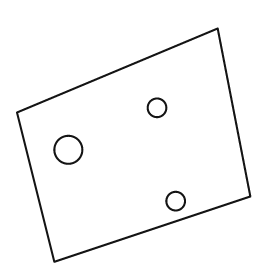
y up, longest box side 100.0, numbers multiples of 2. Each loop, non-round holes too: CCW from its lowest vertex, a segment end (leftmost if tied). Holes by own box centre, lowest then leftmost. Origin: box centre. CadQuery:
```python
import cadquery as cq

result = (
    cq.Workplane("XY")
    .moveTo(-34.0, -50.0)
    .lineTo(50.0, -22.0)
    .lineTo(36.0, 50.0)
    .lineTo(-50.0, 14.0)
    .close()
    .moveTo(18.0, -24.0)
    .circle(4.0)
    .moveTo(-28.0, -2.0)
    .circle(6.0)
    .moveTo(10.0, 16.0)
    .circle(4.0)
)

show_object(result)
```